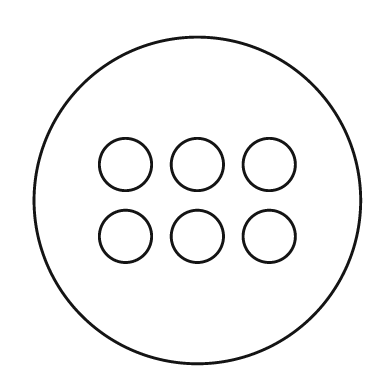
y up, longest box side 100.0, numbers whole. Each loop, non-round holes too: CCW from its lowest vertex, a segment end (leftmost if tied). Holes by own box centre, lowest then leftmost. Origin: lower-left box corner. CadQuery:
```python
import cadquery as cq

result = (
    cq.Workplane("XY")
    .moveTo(50.0, 50.0)
    .circle(50.0)
    .moveTo(28.0, 39.0)
    .circle(8.0)
    .moveTo(50.0, 39.0)
    .circle(8.0)
    .moveTo(72.0, 39.0)
    .circle(8.0)
    .moveTo(28.0, 61.0)
    .circle(8.0)
    .moveTo(50.0, 61.0)
    .circle(8.0)
    .moveTo(72.0, 61.0)
    .circle(8.0)
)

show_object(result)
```